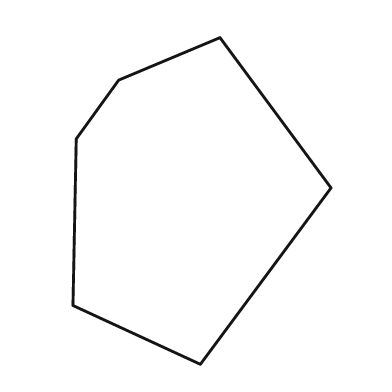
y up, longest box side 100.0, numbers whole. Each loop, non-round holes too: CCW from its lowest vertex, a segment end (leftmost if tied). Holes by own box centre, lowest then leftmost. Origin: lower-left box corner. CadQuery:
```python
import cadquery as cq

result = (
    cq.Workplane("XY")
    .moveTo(39.0, 0.0)
    .lineTo(79.0, 54.0)
    .lineTo(45.0, 100.0)
    .lineTo(14.0, 87.0)
    .lineTo(1.0, 69.0)
    .lineTo(0.0, 18.0)
    .close()
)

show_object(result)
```